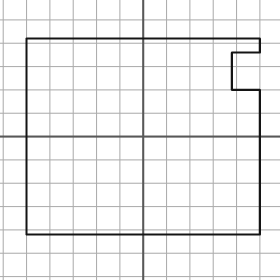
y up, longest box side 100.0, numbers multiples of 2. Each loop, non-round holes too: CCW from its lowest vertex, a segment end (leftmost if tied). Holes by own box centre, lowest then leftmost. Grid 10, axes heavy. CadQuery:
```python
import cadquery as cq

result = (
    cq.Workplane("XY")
    .moveTo(-50.0, -42.0)
    .lineTo(50.0, -42.0)
    .lineTo(50.0, 20.0)
    .lineTo(38.0, 20.0)
    .lineTo(38.0, 36.0)
    .lineTo(50.0, 36.0)
    .lineTo(50.0, 42.0)
    .lineTo(-50.0, 42.0)
    .close()
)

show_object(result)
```